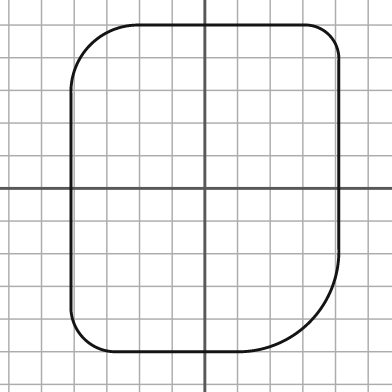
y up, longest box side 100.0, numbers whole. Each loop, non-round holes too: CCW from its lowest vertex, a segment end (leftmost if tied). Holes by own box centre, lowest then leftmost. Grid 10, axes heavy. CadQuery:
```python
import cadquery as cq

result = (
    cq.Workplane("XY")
    .moveTo(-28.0, -50.0)
    .lineTo(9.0, -50.0)
    .threePointArc((32.0, -41.0), (41.0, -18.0))
    .lineTo(41.0, 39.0)
    .threePointArc((38.0, 47.0), (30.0, 50.0))
    .lineTo(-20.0, 50.0)
    .threePointArc((-35.0, 44.0), (-41.0, 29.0))
    .lineTo(-41.0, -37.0)
    .threePointArc((-37.0, -46.0), (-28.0, -50.0))
    .close()
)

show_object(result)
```